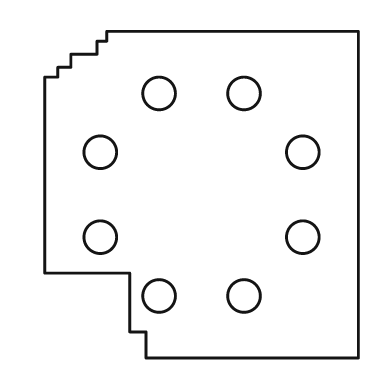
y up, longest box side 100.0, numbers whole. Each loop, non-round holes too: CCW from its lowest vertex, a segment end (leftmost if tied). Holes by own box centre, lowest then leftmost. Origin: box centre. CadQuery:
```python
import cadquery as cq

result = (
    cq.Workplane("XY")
    .moveTo(-17.0, -50.0)
    .lineTo(48.0, -50.0)
    .lineTo(48.0, 50.0)
    .lineTo(-29.0, 50.0)
    .lineTo(-29.0, 47.0)
    .lineTo(-32.0, 47.0)
    .lineTo(-32.0, 43.0)
    .lineTo(-40.0, 43.0)
    .lineTo(-40.0, 39.0)
    .lineTo(-44.0, 39.0)
    .lineTo(-44.0, 36.0)
    .lineTo(-48.0, 36.0)
    .lineTo(-48.0, -24.0)
    .lineTo(-22.0, -24.0)
    .lineTo(-22.0, -42.0)
    .lineTo(-17.0, -42.0)
    .close()
    .moveTo(-13.0, -31.0)
    .circle(5.0)
    .moveTo(13.0, -31.0)
    .circle(5.0)
    .moveTo(-31.0, -13.0)
    .circle(5.0)
    .moveTo(31.0, -13.0)
    .circle(5.0)
    .moveTo(-31.0, 13.0)
    .circle(5.0)
    .moveTo(31.0, 13.0)
    .circle(5.0)
    .moveTo(-13.0, 31.0)
    .circle(5.0)
    .moveTo(13.0, 31.0)
    .circle(5.0)
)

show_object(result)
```